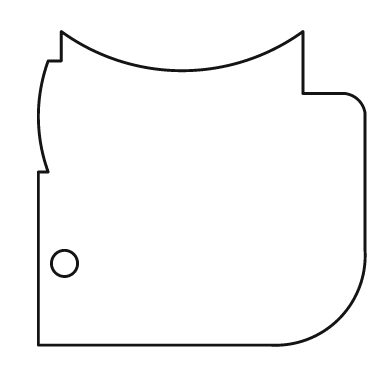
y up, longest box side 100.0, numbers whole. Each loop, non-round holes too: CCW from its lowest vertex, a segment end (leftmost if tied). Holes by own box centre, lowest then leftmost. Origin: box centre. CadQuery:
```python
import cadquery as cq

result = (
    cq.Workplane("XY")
    .moveTo(-50.0, -48.0)
    .lineTo(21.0, -48.0)
    .threePointArc((42.0, -40.0), (50.0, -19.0))
    .lineTo(50.0, 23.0)
    .threePointArc((48.0, 27.0), (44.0, 29.0))
    .lineTo(31.0, 29.0)
    .lineTo(31.0, 48.0)
    .threePointArc((-6.0, 36.0), (-43.0, 48.0))
    .lineTo(-43.0, 39.0)
    .lineTo(-47.0, 39.0)
    .threePointArc((-50.0, 22.0), (-47.0, 5.0))
    .lineTo(-50.0, 5.0)
    .close()
    .moveTo(-42.0, -23.0)
    .circle(4.0)
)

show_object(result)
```